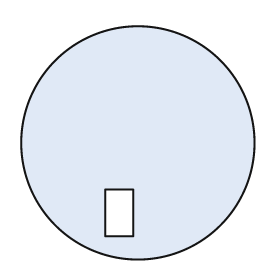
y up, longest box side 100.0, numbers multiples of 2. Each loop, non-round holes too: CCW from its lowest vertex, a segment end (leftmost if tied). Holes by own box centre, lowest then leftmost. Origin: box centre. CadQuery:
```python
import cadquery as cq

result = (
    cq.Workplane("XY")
    .moveTo(0.0, 0.0)
    .circle(50.0)
    .moveTo(-14.0, -40.0)
    .lineTo(-2.0, -40.0)
    .lineTo(-2.0, -20.0)
    .lineTo(-14.0, -20.0)
    .close()
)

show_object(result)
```